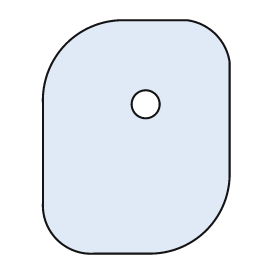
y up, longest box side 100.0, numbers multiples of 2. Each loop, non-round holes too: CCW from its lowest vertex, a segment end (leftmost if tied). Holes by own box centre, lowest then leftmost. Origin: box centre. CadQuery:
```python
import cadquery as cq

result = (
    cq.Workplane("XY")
    .moveTo(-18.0, -50.0)
    .lineTo(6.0, -50.0)
    .threePointArc((30.0, -40.0), (40.0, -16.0))
    .lineTo(40.0, 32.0)
    .threePointArc((34.0, 44.0), (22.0, 50.0))
    .lineTo(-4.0, 50.0)
    .threePointArc((-30.0, 40.0), (-40.0, 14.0))
    .lineTo(-40.0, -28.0)
    .threePointArc((-34.0, -44.0), (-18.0, -50.0))
    .close()
    .moveTo(4.0, 14.0)
    .circle(6.0)
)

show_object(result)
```